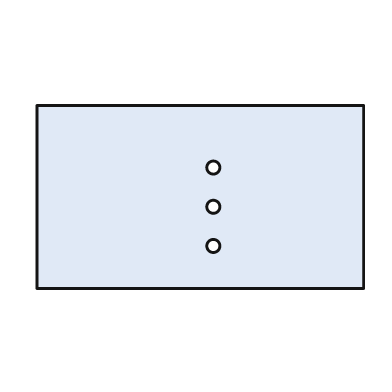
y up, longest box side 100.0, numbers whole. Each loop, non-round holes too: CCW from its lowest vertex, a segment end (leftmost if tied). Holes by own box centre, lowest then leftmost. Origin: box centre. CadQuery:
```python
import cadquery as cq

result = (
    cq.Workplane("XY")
    .moveTo(-50.0, -28.0)
    .lineTo(50.0, -28.0)
    .lineTo(50.0, 28.0)
    .lineTo(-50.0, 28.0)
    .close()
    .moveTo(4.0, -15.0)
    .circle(2.0)
    .moveTo(4.0, -3.0)
    .circle(2.0)
    .moveTo(4.0, 9.0)
    .circle(2.0)
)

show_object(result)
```